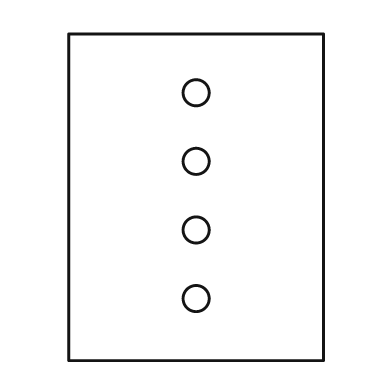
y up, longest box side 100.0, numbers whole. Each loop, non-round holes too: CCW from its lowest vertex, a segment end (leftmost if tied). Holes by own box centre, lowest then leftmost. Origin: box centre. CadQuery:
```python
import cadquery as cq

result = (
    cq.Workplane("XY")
    .moveTo(-39.0, -50.0)
    .lineTo(39.0, -50.0)
    .lineTo(39.0, 50.0)
    .lineTo(-39.0, 50.0)
    .close()
    .moveTo(0.0, -31.0)
    .circle(4.0)
    .moveTo(0.0, -10.0)
    .circle(4.0)
    .moveTo(0.0, 11.0)
    .circle(4.0)
    .moveTo(0.0, 32.0)
    .circle(4.0)
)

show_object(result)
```